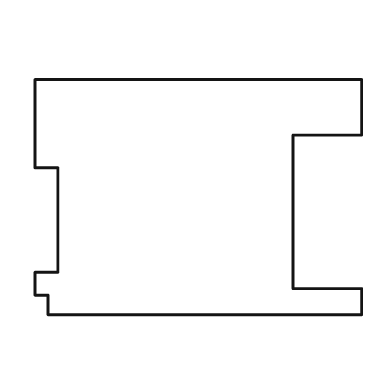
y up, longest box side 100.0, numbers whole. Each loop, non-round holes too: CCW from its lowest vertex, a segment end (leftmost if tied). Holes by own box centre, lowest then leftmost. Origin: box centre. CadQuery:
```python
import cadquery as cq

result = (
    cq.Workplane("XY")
    .moveTo(-46.0, -36.0)
    .lineTo(50.0, -36.0)
    .lineTo(50.0, -28.0)
    .lineTo(29.0, -28.0)
    .lineTo(29.0, 19.0)
    .lineTo(50.0, 19.0)
    .lineTo(50.0, 36.0)
    .lineTo(-50.0, 36.0)
    .lineTo(-50.0, 9.0)
    .lineTo(-43.0, 9.0)
    .lineTo(-43.0, -23.0)
    .lineTo(-50.0, -23.0)
    .lineTo(-50.0, -30.0)
    .lineTo(-46.0, -30.0)
    .close()
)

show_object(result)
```